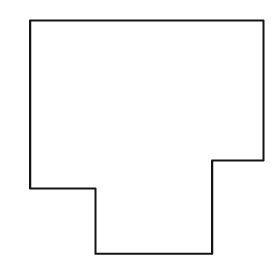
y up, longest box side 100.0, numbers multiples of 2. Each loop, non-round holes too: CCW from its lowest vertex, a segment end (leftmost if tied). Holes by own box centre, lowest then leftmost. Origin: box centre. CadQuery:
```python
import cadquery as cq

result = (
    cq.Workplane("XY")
    .moveTo(-22.0, -50.0)
    .lineTo(28.0, -50.0)
    .lineTo(28.0, -10.0)
    .lineTo(50.0, -10.0)
    .lineTo(50.0, 50.0)
    .lineTo(-50.0, 50.0)
    .lineTo(-50.0, -22.0)
    .lineTo(-22.0, -22.0)
    .close()
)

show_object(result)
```